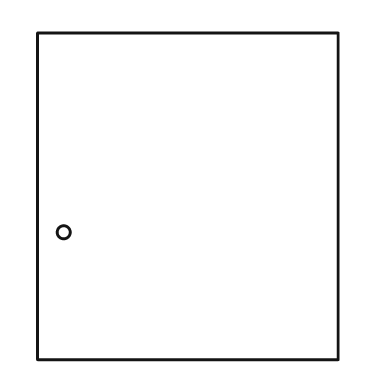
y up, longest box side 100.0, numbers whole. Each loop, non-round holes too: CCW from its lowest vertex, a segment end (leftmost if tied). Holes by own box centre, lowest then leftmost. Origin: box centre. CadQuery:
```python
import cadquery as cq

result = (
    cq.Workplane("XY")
    .moveTo(-46.0, -50.0)
    .lineTo(46.0, -50.0)
    .lineTo(46.0, 50.0)
    .lineTo(-46.0, 50.0)
    .close()
    .moveTo(-38.0, -11.0)
    .circle(2.0)
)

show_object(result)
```